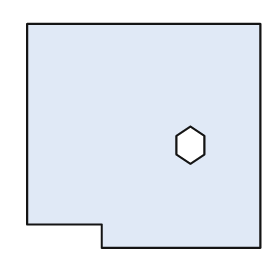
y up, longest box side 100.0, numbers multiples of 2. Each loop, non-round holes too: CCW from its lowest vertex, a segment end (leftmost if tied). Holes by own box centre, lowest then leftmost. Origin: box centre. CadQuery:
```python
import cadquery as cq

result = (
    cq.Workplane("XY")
    .moveTo(-18.0, -48.0)
    .lineTo(50.0, -48.0)
    .lineTo(50.0, 48.0)
    .lineTo(-50.0, 48.0)
    .lineTo(-50.0, -38.0)
    .lineTo(-18.0, -38.0)
    .close()
    .moveTo(20.0, -12.0)
    .lineTo(26.0, -8.0)
    .lineTo(26.0, 0.0)
    .lineTo(20.0, 4.0)
    .lineTo(14.0, 0.0)
    .lineTo(14.0, -8.0)
    .close()
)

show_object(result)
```